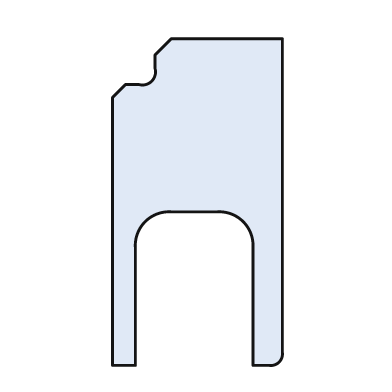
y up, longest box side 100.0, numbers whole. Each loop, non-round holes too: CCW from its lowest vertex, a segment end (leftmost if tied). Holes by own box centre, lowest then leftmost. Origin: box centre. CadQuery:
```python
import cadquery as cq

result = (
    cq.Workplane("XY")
    .moveTo(-26.0, -50.0)
    .lineTo(-19.0, -50.0)
    .lineTo(-19.0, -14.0)
    .threePointArc((-16.0, -6.0), (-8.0, -3.0))
    .lineTo(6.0, -3.0)
    .threePointArc((14.0, -6.0), (17.0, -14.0))
    .lineTo(17.0, -50.0)
    .lineTo(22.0, -50.0)
    .threePointArc((25.0, -49.0), (26.0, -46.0))
    .lineTo(26.0, 50.0)
    .lineTo(-8.0, 50.0)
    .lineTo(-13.0, 45.0)
    .lineTo(-13.0, 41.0)
    .threePointArc((-14.0, 37.0), (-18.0, 36.0))
    .lineTo(-22.0, 36.0)
    .lineTo(-26.0, 32.0)
    .close()
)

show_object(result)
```